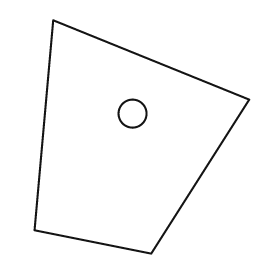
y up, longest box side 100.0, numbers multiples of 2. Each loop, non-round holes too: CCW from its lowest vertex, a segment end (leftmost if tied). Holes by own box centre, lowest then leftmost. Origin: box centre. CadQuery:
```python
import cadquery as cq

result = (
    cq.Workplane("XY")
    .moveTo(4.0, -50.0)
    .lineTo(46.0, 16.0)
    .lineTo(-38.0, 50.0)
    .lineTo(-46.0, -40.0)
    .close()
    .moveTo(-4.0, 10.0)
    .circle(6.0)
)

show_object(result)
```